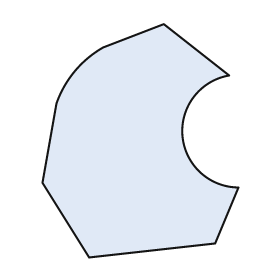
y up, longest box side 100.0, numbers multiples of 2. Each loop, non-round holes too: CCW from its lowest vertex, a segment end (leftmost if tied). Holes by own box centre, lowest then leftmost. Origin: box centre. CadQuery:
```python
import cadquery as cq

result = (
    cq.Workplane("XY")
    .moveTo(-22.0, -50.0)
    .lineTo(32.0, -44.0)
    .lineTo(42.0, -20.0)
    .threePointArc((18.0, 2.0), (38.0, 28.0))
    .lineTo(10.0, 50.0)
    .lineTo(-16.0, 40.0)
    .threePointArc((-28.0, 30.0), (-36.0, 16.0))
    .lineTo(-42.0, -18.0)
    .close()
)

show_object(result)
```